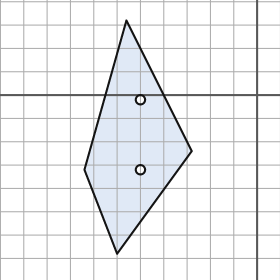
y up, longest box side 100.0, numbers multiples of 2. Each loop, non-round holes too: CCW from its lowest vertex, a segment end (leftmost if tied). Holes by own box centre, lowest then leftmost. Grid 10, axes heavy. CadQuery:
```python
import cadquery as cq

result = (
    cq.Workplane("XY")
    .moveTo(-60.0, -68.0)
    .lineTo(-28.0, -24.0)
    .lineTo(-56.0, 32.0)
    .lineTo(-74.0, -32.0)
    .close()
    .moveTo(-50.0, -32.0)
    .circle(2.0)
    .moveTo(-50.0, -2.0)
    .circle(2.0)
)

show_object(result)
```